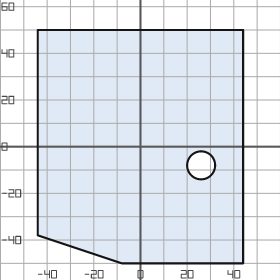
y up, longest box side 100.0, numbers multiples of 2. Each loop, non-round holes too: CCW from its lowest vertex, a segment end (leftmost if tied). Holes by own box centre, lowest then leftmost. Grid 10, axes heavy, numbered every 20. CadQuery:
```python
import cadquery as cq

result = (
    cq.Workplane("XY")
    .moveTo(-8.0, -50.0)
    .lineTo(44.0, -50.0)
    .lineTo(44.0, 50.0)
    .lineTo(-44.0, 50.0)
    .lineTo(-44.0, -38.0)
    .close()
    .moveTo(26.0, -8.0)
    .circle(6.0)
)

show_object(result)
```